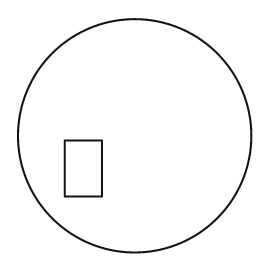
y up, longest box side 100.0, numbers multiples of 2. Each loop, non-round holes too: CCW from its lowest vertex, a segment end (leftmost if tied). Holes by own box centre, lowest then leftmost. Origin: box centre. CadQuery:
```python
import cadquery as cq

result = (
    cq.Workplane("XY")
    .moveTo(0.0, 0.0)
    .circle(50.0)
    .moveTo(-30.0, -26.0)
    .lineTo(-14.0, -26.0)
    .lineTo(-14.0, -2.0)
    .lineTo(-30.0, -2.0)
    .close()
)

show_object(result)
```